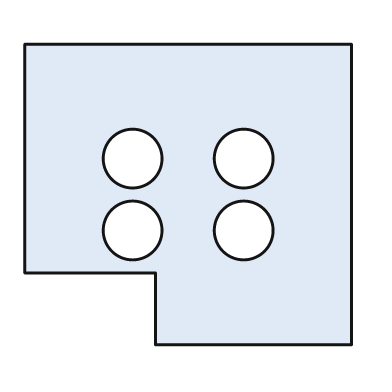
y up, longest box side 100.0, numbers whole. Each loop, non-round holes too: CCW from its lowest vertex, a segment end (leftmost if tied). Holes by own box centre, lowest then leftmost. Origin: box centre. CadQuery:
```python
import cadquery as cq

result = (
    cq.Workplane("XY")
    .moveTo(-10.0, -46.0)
    .lineTo(50.0, -46.0)
    .lineTo(50.0, 46.0)
    .lineTo(-50.0, 46.0)
    .lineTo(-50.0, -24.0)
    .lineTo(-10.0, -24.0)
    .close()
    .moveTo(-17.0, -11.0)
    .circle(9.0)
    .moveTo(17.0, -11.0)
    .circle(9.0)
    .moveTo(-17.0, 11.0)
    .circle(9.0)
    .moveTo(17.0, 11.0)
    .circle(9.0)
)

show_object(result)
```